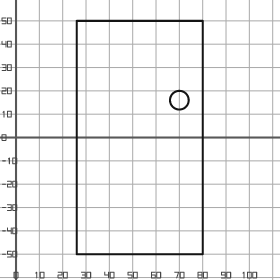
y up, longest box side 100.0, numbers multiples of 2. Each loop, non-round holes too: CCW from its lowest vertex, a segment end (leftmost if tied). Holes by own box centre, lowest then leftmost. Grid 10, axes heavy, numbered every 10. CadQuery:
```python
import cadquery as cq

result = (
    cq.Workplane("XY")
    .moveTo(26.0, -50.0)
    .lineTo(80.0, -50.0)
    .lineTo(80.0, 50.0)
    .lineTo(26.0, 50.0)
    .close()
    .moveTo(70.0, 16.0)
    .circle(4.0)
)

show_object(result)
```